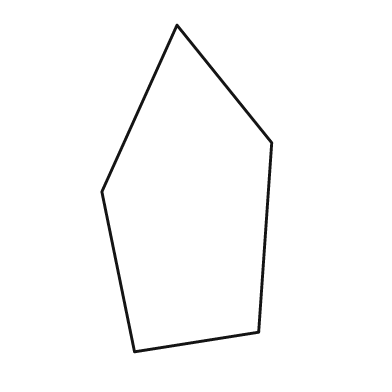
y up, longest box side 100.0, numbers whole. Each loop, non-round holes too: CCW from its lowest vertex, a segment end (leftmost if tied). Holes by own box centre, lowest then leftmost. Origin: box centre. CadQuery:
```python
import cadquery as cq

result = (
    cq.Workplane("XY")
    .moveTo(-16.0, -50.0)
    .lineTo(22.0, -44.0)
    .lineTo(26.0, 14.0)
    .lineTo(-3.0, 50.0)
    .lineTo(-26.0, -1.0)
    .close()
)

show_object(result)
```